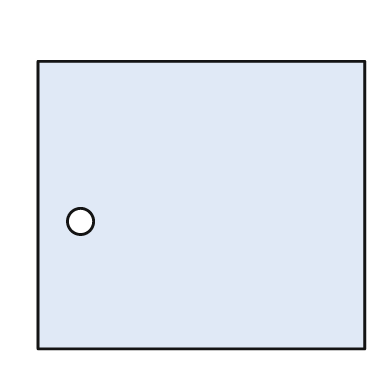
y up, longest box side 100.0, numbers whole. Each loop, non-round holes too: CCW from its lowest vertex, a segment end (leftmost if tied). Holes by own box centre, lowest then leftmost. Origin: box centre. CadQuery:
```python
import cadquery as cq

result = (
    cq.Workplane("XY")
    .moveTo(-50.0, -44.0)
    .lineTo(50.0, -44.0)
    .lineTo(50.0, 44.0)
    .lineTo(-50.0, 44.0)
    .close()
    .moveTo(-37.0, -5.0)
    .circle(4.0)
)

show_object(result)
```